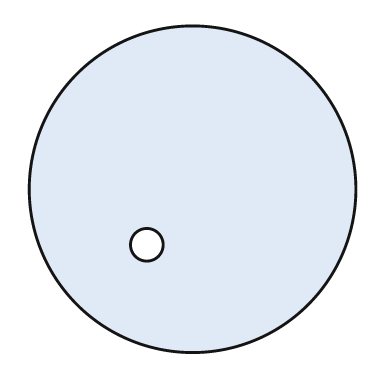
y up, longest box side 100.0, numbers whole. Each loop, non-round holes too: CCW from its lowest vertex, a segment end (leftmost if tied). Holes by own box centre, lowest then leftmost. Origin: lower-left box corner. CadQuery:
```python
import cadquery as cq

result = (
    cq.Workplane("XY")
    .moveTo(50.0, 50.0)
    .circle(50.0)
    .moveTo(36.0, 33.0)
    .circle(5.0)
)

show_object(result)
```